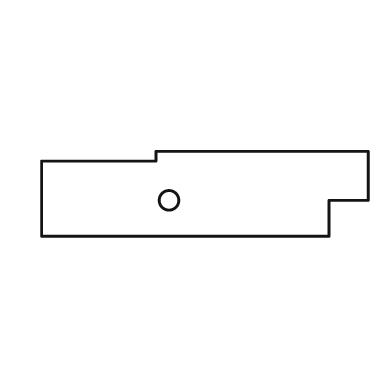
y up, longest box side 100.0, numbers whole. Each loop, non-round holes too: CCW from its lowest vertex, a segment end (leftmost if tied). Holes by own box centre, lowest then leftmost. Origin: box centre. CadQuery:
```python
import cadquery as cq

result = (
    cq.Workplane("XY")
    .moveTo(-50.0, -13.0)
    .lineTo(38.0, -13.0)
    .lineTo(38.0, -2.0)
    .lineTo(50.0, -2.0)
    .lineTo(50.0, 13.0)
    .lineTo(-15.0, 13.0)
    .lineTo(-15.0, 10.0)
    .lineTo(-50.0, 10.0)
    .close()
    .moveTo(-11.0, -2.0)
    .circle(3.0)
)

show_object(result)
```